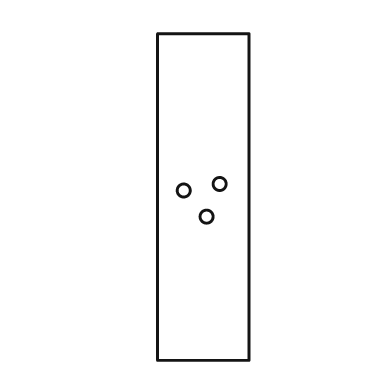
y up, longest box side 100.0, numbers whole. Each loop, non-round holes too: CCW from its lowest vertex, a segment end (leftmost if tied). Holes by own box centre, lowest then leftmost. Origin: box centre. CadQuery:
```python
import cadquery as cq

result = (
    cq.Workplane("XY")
    .moveTo(-14.0, -50.0)
    .lineTo(14.0, -50.0)
    .lineTo(14.0, 50.0)
    .lineTo(-14.0, 50.0)
    .close()
    .moveTo(1.0, -6.0)
    .circle(2.0)
    .moveTo(-6.0, 2.0)
    .circle(2.0)
    .moveTo(5.0, 4.0)
    .circle(2.0)
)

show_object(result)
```